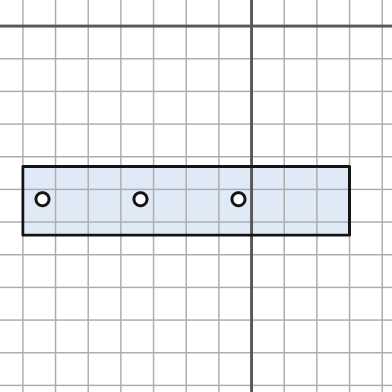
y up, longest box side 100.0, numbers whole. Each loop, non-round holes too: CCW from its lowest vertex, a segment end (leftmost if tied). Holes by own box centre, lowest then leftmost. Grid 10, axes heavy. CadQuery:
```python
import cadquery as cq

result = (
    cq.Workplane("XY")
    .moveTo(-70.0, -64.0)
    .lineTo(30.0, -64.0)
    .lineTo(30.0, -43.0)
    .lineTo(-70.0, -43.0)
    .close()
    .moveTo(-64.0, -53.0)
    .circle(2.0)
    .moveTo(-34.0, -53.0)
    .circle(2.0)
    .moveTo(-4.0, -53.0)
    .circle(2.0)
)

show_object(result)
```